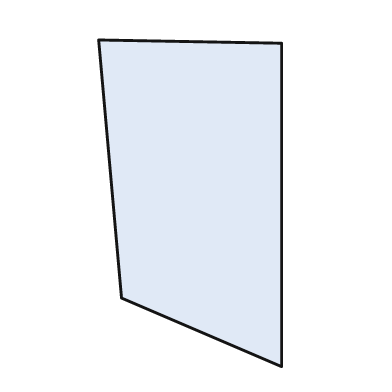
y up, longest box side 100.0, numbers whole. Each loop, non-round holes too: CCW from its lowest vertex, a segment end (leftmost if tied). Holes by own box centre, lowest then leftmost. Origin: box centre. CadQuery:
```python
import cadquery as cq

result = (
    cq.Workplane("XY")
    .moveTo(28.0, -50.0)
    .lineTo(28.0, 49.0)
    .lineTo(-28.0, 50.0)
    .lineTo(-21.0, -29.0)
    .close()
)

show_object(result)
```